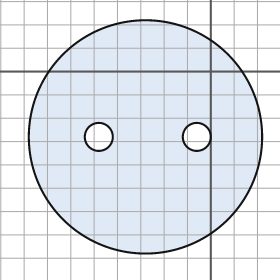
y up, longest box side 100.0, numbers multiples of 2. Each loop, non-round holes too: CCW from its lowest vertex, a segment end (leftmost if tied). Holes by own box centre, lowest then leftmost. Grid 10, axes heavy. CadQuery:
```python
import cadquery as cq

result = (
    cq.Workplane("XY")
    .moveTo(-28.0, -28.0)
    .circle(50.0)
    .moveTo(-48.0, -28.0)
    .circle(6.0)
    .moveTo(-6.0, -28.0)
    .circle(6.0)
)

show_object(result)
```